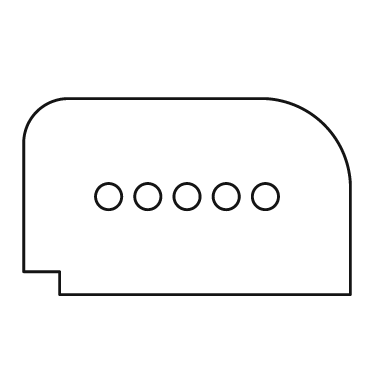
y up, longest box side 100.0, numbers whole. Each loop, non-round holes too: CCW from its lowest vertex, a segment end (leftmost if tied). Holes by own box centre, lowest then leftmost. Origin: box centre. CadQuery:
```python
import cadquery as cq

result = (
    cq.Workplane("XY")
    .moveTo(-39.0, -30.0)
    .lineTo(50.0, -30.0)
    .lineTo(50.0, 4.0)
    .threePointArc((42.0, 22.0), (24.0, 30.0))
    .lineTo(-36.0, 30.0)
    .threePointArc((-46.0, 26.0), (-50.0, 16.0))
    .lineTo(-50.0, -23.0)
    .lineTo(-39.0, -23.0)
    .close()
    .moveTo(-24.0, 0.0)
    .circle(4.0)
    .moveTo(-12.0, 0.0)
    .circle(4.0)
    .moveTo(0.0, 0.0)
    .circle(4.0)
    .moveTo(12.0, 0.0)
    .circle(4.0)
    .moveTo(24.0, 0.0)
    .circle(4.0)
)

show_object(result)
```